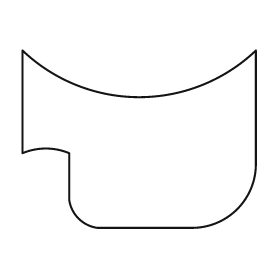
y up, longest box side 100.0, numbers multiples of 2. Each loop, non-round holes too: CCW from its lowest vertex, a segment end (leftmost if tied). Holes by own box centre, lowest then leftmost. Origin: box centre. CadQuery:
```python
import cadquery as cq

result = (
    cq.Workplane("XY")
    .moveTo(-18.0, -38.0)
    .lineTo(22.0, -38.0)
    .threePointArc((42.0, -30.0), (50.0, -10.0))
    .lineTo(50.0, 38.0)
    .threePointArc((0.0, 18.0), (-50.0, 38.0))
    .lineTo(-50.0, -6.0)
    .threePointArc((-40.0, -4.0), (-30.0, -6.0))
    .lineTo(-30.0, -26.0)
    .threePointArc((-26.0, -34.0), (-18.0, -38.0))
    .close()
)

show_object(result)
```